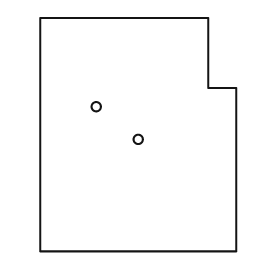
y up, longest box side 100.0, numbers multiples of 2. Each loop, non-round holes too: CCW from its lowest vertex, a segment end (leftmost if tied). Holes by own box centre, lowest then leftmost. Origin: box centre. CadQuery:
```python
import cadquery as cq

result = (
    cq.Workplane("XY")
    .moveTo(-42.0, -50.0)
    .lineTo(42.0, -50.0)
    .lineTo(42.0, 20.0)
    .lineTo(30.0, 20.0)
    .lineTo(30.0, 50.0)
    .lineTo(-42.0, 50.0)
    .close()
    .moveTo(0.0, -2.0)
    .circle(2.0)
    .moveTo(-18.0, 12.0)
    .circle(2.0)
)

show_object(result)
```